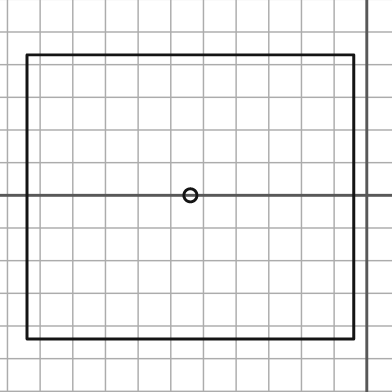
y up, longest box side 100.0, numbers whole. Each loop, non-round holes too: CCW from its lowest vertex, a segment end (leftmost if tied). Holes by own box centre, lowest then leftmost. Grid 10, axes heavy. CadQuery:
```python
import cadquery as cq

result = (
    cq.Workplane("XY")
    .moveTo(-104.0, -44.0)
    .lineTo(-4.0, -44.0)
    .lineTo(-4.0, 43.0)
    .lineTo(-104.0, 43.0)
    .close()
    .moveTo(-54.0, 0.0)
    .circle(2.0)
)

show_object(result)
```